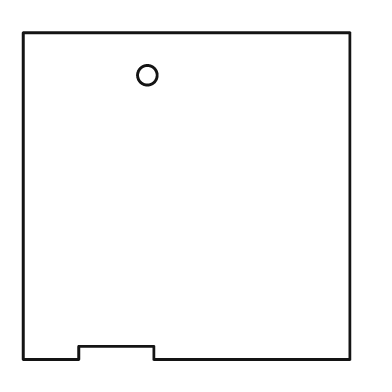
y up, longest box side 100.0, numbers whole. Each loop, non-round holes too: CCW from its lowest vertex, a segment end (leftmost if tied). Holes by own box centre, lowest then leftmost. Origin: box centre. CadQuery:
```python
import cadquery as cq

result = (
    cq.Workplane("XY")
    .moveTo(-50.0, -50.0)
    .lineTo(-33.0, -50.0)
    .lineTo(-33.0, -46.0)
    .lineTo(-10.0, -46.0)
    .lineTo(-10.0, -50.0)
    .lineTo(50.0, -50.0)
    .lineTo(50.0, 50.0)
    .lineTo(-50.0, 50.0)
    .close()
    .moveTo(-12.0, 37.0)
    .circle(3.0)
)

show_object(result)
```